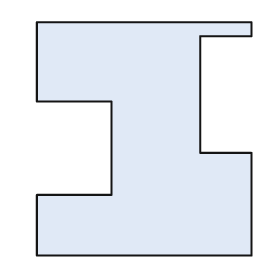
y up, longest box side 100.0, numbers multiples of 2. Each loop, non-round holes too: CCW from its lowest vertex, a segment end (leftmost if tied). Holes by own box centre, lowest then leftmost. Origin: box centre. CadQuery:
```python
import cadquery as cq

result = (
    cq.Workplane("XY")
    .moveTo(-46.0, -50.0)
    .lineTo(46.0, -50.0)
    .lineTo(46.0, -6.0)
    .lineTo(24.0, -6.0)
    .lineTo(24.0, 44.0)
    .lineTo(46.0, 44.0)
    .lineTo(46.0, 50.0)
    .lineTo(-46.0, 50.0)
    .lineTo(-46.0, 16.0)
    .lineTo(-14.0, 16.0)
    .lineTo(-14.0, -24.0)
    .lineTo(-46.0, -24.0)
    .close()
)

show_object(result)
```